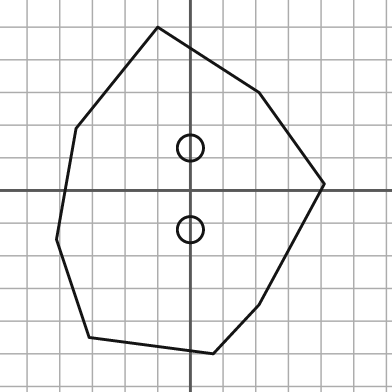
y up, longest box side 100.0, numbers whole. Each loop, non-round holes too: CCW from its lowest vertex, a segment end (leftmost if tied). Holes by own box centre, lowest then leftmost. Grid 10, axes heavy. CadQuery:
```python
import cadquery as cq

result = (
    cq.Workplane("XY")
    .moveTo(7.0, -50.0)
    .lineTo(21.0, -35.0)
    .lineTo(41.0, 2.0)
    .lineTo(21.0, 30.0)
    .lineTo(-10.0, 50.0)
    .lineTo(-35.0, 19.0)
    .lineTo(-41.0, -15.0)
    .lineTo(-31.0, -45.0)
    .close()
    .moveTo(0.0, -12.0)
    .circle(4.0)
    .moveTo(0.0, 13.0)
    .circle(4.0)
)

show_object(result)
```